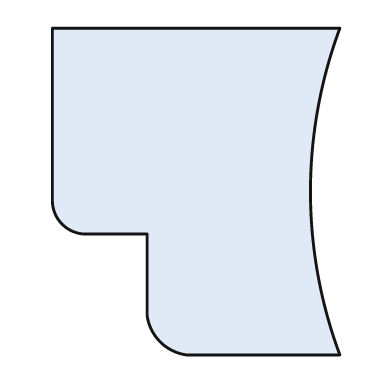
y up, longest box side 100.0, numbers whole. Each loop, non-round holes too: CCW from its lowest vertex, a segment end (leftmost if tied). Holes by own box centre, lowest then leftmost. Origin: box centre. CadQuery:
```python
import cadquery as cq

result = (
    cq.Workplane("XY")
    .moveTo(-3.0, -50.0)
    .lineTo(44.0, -50.0)
    .threePointArc((35.0, 0.0), (44.0, 50.0))
    .lineTo(-44.0, 50.0)
    .lineTo(-44.0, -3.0)
    .threePointArc((-41.0, -10.0), (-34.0, -13.0))
    .lineTo(-15.0, -13.0)
    .lineTo(-15.0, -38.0)
    .threePointArc((-11.0, -46.0), (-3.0, -50.0))
    .close()
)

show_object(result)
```